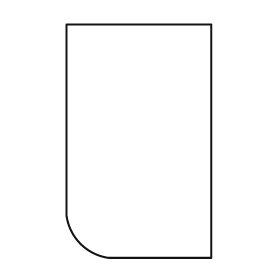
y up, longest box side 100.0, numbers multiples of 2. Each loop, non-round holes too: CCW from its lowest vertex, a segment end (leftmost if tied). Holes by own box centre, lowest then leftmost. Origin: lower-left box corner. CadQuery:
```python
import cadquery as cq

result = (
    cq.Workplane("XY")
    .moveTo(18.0, 0.0)
    .lineTo(62.0, 0.0)
    .lineTo(62.0, 100.0)
    .lineTo(0.0, 100.0)
    .lineTo(0.0, 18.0)
    .threePointArc((6.0, 6.0), (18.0, 0.0))
    .close()
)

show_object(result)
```